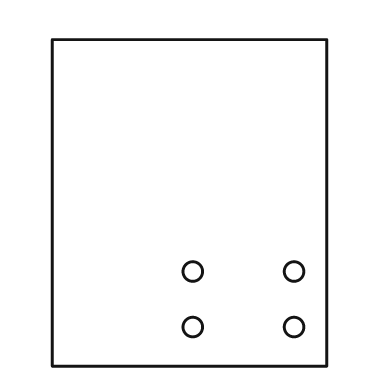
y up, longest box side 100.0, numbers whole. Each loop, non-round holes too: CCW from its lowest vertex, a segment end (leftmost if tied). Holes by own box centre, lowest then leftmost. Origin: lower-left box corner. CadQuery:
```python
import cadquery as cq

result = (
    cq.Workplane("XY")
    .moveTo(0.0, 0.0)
    .lineTo(84.0, 0.0)
    .lineTo(84.0, 100.0)
    .lineTo(0.0, 100.0)
    .close()
    .moveTo(43.0, 12.0)
    .circle(3.0)
    .moveTo(74.0, 12.0)
    .circle(3.0)
    .moveTo(43.0, 29.0)
    .circle(3.0)
    .moveTo(74.0, 29.0)
    .circle(3.0)
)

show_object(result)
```